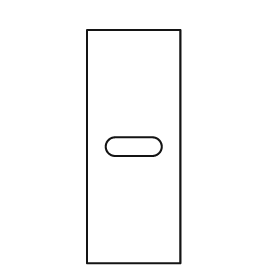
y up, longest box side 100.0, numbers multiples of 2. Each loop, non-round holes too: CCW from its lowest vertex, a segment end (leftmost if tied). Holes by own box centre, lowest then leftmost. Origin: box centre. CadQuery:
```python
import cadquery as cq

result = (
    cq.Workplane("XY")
    .moveTo(-20.0, -50.0)
    .lineTo(20.0, -50.0)
    .lineTo(20.0, 50.0)
    .lineTo(-20.0, 50.0)
    .close()
    .moveTo(-8.0, -4.0)
    .lineTo(8.0, -4.0)
    .threePointArc((12.0, 0.0), (8.0, 4.0))
    .lineTo(-8.0, 4.0)
    .threePointArc((-12.0, 0.0), (-8.0, -4.0))
    .close()
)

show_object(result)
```